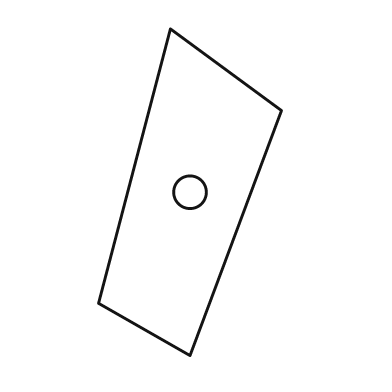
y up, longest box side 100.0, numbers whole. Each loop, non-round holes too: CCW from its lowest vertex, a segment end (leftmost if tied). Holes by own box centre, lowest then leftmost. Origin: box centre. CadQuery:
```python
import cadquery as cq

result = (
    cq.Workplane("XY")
    .moveTo(0.0, -50.0)
    .lineTo(28.0, 25.0)
    .lineTo(-6.0, 50.0)
    .lineTo(-28.0, -34.0)
    .close()
    .moveTo(0.0, 0.0)
    .circle(5.0)
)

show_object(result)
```